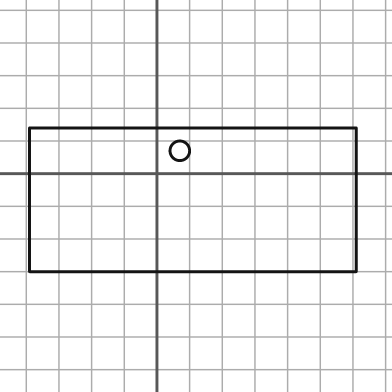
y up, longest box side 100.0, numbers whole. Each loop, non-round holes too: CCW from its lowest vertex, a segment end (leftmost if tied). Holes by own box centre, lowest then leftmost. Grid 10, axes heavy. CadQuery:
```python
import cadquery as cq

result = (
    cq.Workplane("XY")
    .moveTo(-39.0, -30.0)
    .lineTo(61.0, -30.0)
    .lineTo(61.0, 14.0)
    .lineTo(-39.0, 14.0)
    .close()
    .moveTo(7.0, 7.0)
    .circle(3.0)
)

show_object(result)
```